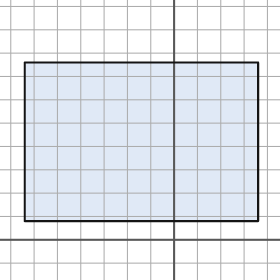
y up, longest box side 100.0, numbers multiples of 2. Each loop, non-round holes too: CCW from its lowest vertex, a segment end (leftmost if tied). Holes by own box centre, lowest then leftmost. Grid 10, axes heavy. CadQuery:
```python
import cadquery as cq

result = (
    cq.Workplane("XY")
    .moveTo(-64.0, 8.0)
    .lineTo(36.0, 8.0)
    .lineTo(36.0, 76.0)
    .lineTo(-64.0, 76.0)
    .close()
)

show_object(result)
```